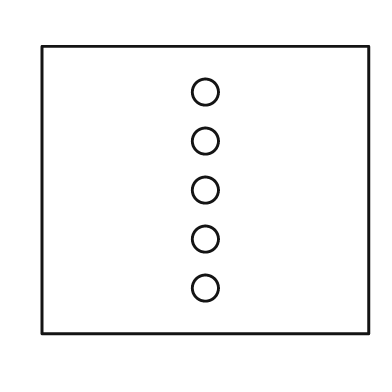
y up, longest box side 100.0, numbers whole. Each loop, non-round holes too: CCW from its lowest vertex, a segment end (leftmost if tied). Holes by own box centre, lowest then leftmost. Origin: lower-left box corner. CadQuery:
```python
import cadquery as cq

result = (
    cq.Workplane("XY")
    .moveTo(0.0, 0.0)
    .lineTo(100.0, 0.0)
    .lineTo(100.0, 88.0)
    .lineTo(0.0, 88.0)
    .close()
    .moveTo(50.0, 14.0)
    .circle(4.0)
    .moveTo(50.0, 29.0)
    .circle(4.0)
    .moveTo(50.0, 44.0)
    .circle(4.0)
    .moveTo(50.0, 59.0)
    .circle(4.0)
    .moveTo(50.0, 74.0)
    .circle(4.0)
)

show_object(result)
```